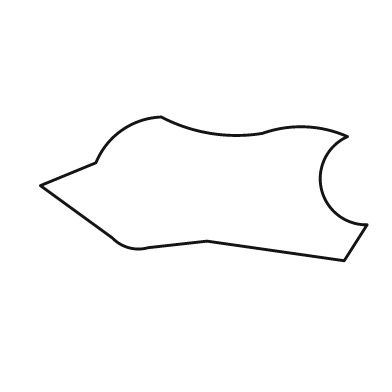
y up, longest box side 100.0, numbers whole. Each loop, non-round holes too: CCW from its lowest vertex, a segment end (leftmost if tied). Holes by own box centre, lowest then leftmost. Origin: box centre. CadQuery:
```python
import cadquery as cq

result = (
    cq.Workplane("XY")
    .moveTo(43.0, -22.0)
    .lineTo(50.0, -11.0)
    .threePointArc((36.0, 0.0), (44.0, 16.0))
    .threePointArc((31.0, 19.0), (18.0, 17.0))
    .threePointArc((2.0, 17.0), (-13.0, 22.0))
    .threePointArc((-25.0, 18.0), (-33.0, 8.0))
    .lineTo(-50.0, 1.0)
    .lineTo(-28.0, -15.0)
    .threePointArc((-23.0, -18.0), (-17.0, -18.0))
    .lineTo(1.0, -16.0)
    .close()
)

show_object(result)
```